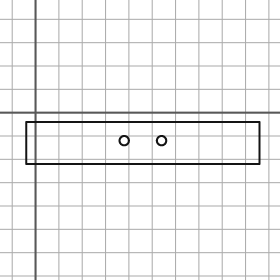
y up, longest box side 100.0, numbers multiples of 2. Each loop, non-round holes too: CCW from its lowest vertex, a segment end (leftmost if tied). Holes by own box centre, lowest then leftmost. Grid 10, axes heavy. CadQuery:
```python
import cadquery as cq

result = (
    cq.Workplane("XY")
    .moveTo(-4.0, -22.0)
    .lineTo(96.0, -22.0)
    .lineTo(96.0, -4.0)
    .lineTo(-4.0, -4.0)
    .close()
    .moveTo(38.0, -12.0)
    .circle(2.0)
    .moveTo(54.0, -12.0)
    .circle(2.0)
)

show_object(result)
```